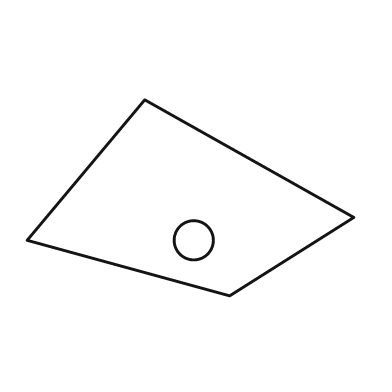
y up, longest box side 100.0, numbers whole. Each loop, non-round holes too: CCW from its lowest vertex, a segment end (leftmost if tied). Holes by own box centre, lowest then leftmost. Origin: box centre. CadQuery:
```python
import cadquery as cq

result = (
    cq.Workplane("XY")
    .moveTo(12.0, -30.0)
    .lineTo(50.0, -6.0)
    .lineTo(-14.0, 30.0)
    .lineTo(-50.0, -13.0)
    .close()
    .moveTo(1.0, -13.0)
    .circle(6.0)
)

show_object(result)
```